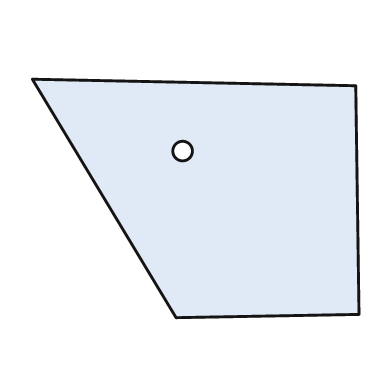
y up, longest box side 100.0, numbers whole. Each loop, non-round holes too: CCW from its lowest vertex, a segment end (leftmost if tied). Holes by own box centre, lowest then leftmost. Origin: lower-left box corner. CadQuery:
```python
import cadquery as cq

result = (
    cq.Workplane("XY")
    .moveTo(44.0, 0.0)
    .lineTo(100.0, 1.0)
    .lineTo(99.0, 71.0)
    .lineTo(0.0, 73.0)
    .close()
    .moveTo(46.0, 51.0)
    .circle(3.0)
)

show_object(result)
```